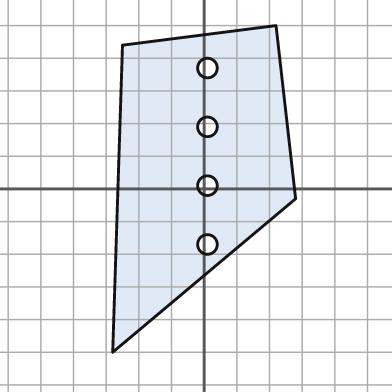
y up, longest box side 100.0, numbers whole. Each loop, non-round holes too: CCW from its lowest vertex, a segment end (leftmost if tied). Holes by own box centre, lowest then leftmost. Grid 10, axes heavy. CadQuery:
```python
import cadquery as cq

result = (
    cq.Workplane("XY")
    .moveTo(-28.0, -50.0)
    .lineTo(28.0, -3.0)
    .lineTo(22.0, 50.0)
    .lineTo(-25.0, 44.0)
    .close()
    .moveTo(1.0, -17.0)
    .circle(3.0)
    .moveTo(1.0, 1.0)
    .circle(3.0)
    .moveTo(1.0, 19.0)
    .circle(3.0)
    .moveTo(1.0, 37.0)
    .circle(3.0)
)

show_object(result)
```